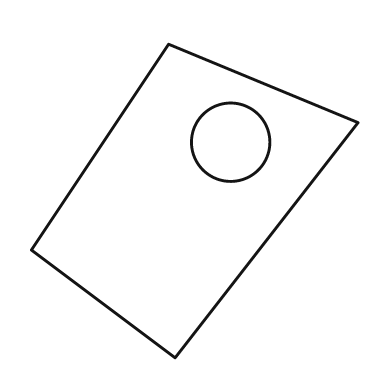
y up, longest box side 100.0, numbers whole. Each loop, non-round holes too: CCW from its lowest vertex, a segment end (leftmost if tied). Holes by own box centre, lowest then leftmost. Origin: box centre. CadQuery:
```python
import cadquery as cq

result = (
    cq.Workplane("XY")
    .moveTo(-6.0, -48.0)
    .lineTo(50.0, 24.0)
    .lineTo(-8.0, 48.0)
    .lineTo(-50.0, -15.0)
    .close()
    .moveTo(11.0, 18.0)
    .circle(12.0)
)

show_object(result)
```